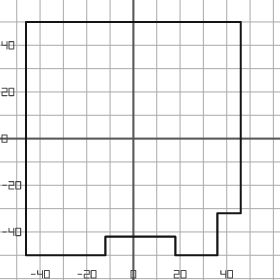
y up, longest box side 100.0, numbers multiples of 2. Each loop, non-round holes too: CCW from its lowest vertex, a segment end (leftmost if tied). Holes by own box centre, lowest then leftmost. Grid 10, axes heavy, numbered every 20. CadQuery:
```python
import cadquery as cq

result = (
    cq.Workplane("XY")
    .moveTo(-46.0, -50.0)
    .lineTo(-12.0, -50.0)
    .lineTo(-12.0, -42.0)
    .lineTo(18.0, -42.0)
    .lineTo(18.0, -50.0)
    .lineTo(36.0, -50.0)
    .lineTo(36.0, -32.0)
    .lineTo(46.0, -32.0)
    .lineTo(46.0, 50.0)
    .lineTo(-46.0, 50.0)
    .close()
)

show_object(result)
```